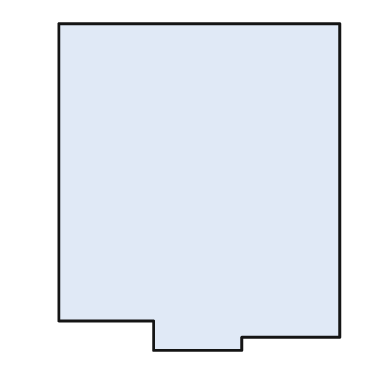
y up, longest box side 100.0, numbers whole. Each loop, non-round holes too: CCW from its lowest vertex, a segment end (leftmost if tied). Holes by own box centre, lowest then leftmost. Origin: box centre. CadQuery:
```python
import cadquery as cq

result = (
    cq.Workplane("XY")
    .moveTo(-14.0, -50.0)
    .lineTo(13.0, -50.0)
    .lineTo(13.0, -46.0)
    .lineTo(43.0, -46.0)
    .lineTo(43.0, 50.0)
    .lineTo(-43.0, 50.0)
    .lineTo(-43.0, -41.0)
    .lineTo(-14.0, -41.0)
    .close()
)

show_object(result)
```